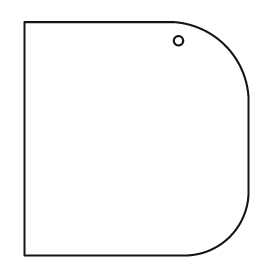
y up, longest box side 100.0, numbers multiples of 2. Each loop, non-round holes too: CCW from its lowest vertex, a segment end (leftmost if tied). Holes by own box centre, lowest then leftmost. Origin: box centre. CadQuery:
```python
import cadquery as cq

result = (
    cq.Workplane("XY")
    .moveTo(-48.0, -50.0)
    .lineTo(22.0, -50.0)
    .threePointArc((40.0, -42.0), (48.0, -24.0))
    .lineTo(48.0, 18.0)
    .threePointArc((38.0, 40.0), (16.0, 50.0))
    .lineTo(-48.0, 50.0)
    .close()
    .moveTo(18.0, 42.0)
    .circle(2.0)
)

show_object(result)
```